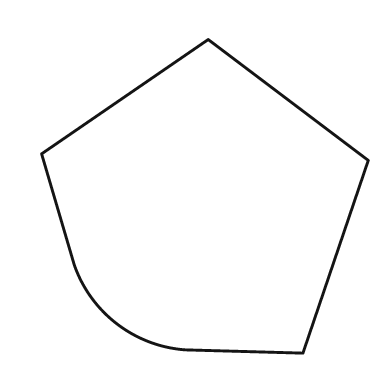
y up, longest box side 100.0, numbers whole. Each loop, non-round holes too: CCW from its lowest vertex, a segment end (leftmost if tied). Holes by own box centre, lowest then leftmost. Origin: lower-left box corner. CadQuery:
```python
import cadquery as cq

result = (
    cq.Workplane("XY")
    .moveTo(80.0, 0.0)
    .lineTo(100.0, 59.0)
    .lineTo(51.0, 96.0)
    .lineTo(0.0, 61.0)
    .lineTo(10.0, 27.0)
    .threePointArc((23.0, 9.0), (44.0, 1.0))
    .close()
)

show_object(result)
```